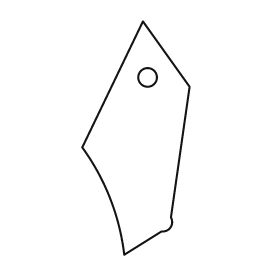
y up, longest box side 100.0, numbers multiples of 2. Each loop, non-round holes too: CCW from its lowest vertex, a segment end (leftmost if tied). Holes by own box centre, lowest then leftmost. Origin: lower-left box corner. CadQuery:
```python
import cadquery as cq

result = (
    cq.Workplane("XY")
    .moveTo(18.0, 0.0)
    .lineTo(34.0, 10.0)
    .threePointArc((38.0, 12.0), (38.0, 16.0))
    .lineTo(46.0, 72.0)
    .lineTo(26.0, 100.0)
    .lineTo(0.0, 46.0)
    .threePointArc((12.0, 24.0), (18.0, 0.0))
    .close()
    .moveTo(28.0, 76.0)
    .circle(4.0)
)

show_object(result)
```